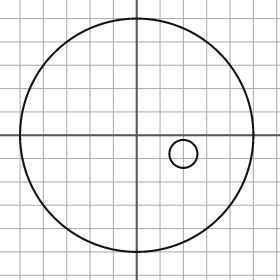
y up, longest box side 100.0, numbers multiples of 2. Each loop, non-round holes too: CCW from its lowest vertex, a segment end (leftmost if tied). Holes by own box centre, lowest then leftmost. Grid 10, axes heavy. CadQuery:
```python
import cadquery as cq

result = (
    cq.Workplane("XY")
    .moveTo(0.0, 0.0)
    .circle(50.0)
    .moveTo(20.0, -8.0)
    .circle(6.0)
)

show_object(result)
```